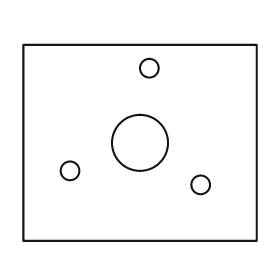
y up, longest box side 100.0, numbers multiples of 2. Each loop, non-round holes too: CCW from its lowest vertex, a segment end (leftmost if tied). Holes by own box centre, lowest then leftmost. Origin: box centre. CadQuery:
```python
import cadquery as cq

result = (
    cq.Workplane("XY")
    .moveTo(-50.0, -42.0)
    .lineTo(50.0, -42.0)
    .lineTo(50.0, 42.0)
    .lineTo(-50.0, 42.0)
    .close()
    .moveTo(26.0, -18.0)
    .circle(4.0)
    .moveTo(-30.0, -12.0)
    .circle(4.0)
    .moveTo(0.0, 0.0)
    .circle(12.0)
    .moveTo(4.0, 32.0)
    .circle(4.0)
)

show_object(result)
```